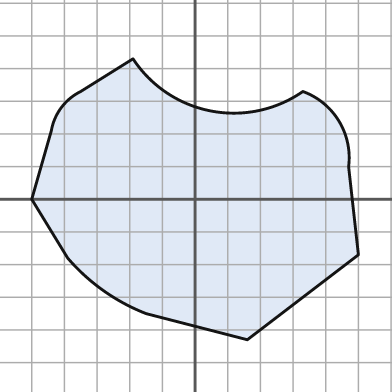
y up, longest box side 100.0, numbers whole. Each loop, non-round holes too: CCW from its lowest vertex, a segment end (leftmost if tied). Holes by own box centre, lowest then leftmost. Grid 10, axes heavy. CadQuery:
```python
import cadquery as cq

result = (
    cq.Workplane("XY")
    .moveTo(16.0, -43.0)
    .lineTo(50.0, -17.0)
    .lineTo(47.0, 10.0)
    .threePointArc((44.0, 24.0), (33.0, 33.0))
    .threePointArc((5.0, 27.0), (-19.0, 43.0))
    .lineTo(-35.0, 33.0)
    .threePointArc((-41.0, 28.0), (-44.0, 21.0))
    .lineTo(-50.0, 0.0)
    .lineTo(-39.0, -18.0)
    .threePointArc((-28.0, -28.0), (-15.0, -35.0))
    .close()
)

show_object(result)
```